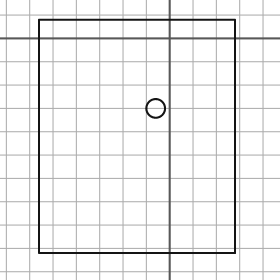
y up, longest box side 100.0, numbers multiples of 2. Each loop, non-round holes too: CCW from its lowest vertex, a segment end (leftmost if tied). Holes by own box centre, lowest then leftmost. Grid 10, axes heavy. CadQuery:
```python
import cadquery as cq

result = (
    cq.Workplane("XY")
    .moveTo(-56.0, -92.0)
    .lineTo(28.0, -92.0)
    .lineTo(28.0, 8.0)
    .lineTo(-56.0, 8.0)
    .close()
    .moveTo(-6.0, -30.0)
    .circle(4.0)
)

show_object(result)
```